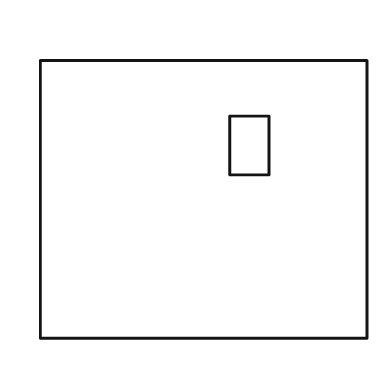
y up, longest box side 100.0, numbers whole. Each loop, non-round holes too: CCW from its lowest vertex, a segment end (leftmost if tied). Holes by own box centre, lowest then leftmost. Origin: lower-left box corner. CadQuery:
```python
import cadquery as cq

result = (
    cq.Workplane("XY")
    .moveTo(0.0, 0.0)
    .lineTo(100.0, 0.0)
    .lineTo(100.0, 85.0)
    .lineTo(0.0, 85.0)
    .close()
    .moveTo(58.0, 50.0)
    .lineTo(70.0, 50.0)
    .lineTo(70.0, 68.0)
    .lineTo(58.0, 68.0)
    .close()
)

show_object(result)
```